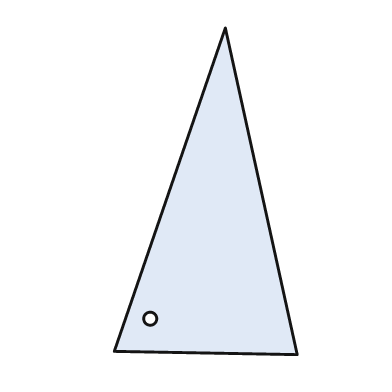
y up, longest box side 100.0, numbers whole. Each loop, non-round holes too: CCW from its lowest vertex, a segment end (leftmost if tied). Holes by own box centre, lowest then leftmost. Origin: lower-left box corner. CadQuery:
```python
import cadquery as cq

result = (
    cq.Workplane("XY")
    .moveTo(56.0, 0.0)
    .lineTo(34.0, 100.0)
    .lineTo(0.0, 1.0)
    .close()
    .moveTo(11.0, 11.0)
    .circle(2.0)
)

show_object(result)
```